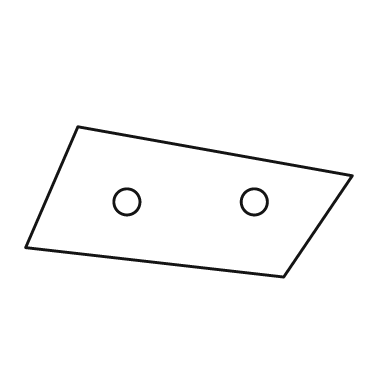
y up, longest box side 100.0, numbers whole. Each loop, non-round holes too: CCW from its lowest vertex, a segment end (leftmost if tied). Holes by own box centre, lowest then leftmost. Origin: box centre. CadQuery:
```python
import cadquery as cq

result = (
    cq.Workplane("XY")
    .moveTo(29.0, -23.0)
    .lineTo(50.0, 8.0)
    .lineTo(-34.0, 23.0)
    .lineTo(-50.0, -14.0)
    .close()
    .moveTo(-19.0, 0.0)
    .circle(4.0)
    .moveTo(20.0, 0.0)
    .circle(4.0)
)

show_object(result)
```